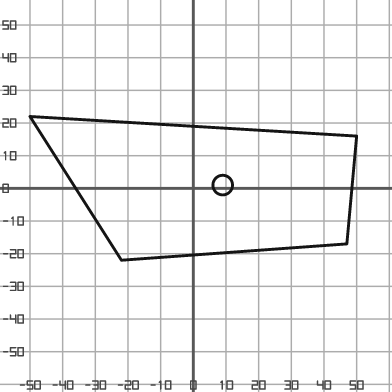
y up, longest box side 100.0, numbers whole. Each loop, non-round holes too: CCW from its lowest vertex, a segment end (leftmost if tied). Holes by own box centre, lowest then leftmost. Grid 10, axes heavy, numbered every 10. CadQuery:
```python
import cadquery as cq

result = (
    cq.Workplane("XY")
    .moveTo(-22.0, -22.0)
    .lineTo(47.0, -17.0)
    .lineTo(50.0, 16.0)
    .lineTo(-50.0, 22.0)
    .close()
    .moveTo(9.0, 1.0)
    .circle(3.0)
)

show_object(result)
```